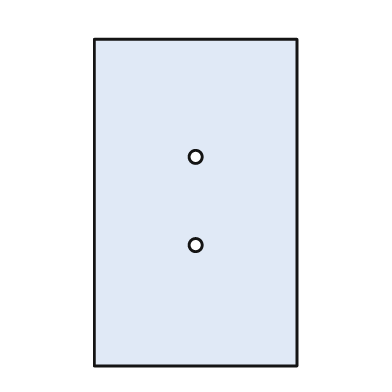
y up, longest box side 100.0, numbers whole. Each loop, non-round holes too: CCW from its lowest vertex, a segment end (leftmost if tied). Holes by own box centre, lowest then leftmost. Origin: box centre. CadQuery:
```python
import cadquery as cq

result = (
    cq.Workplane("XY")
    .moveTo(-31.0, -50.0)
    .lineTo(31.0, -50.0)
    .lineTo(31.0, 50.0)
    .lineTo(-31.0, 50.0)
    .close()
    .moveTo(0.0, -13.0)
    .circle(2.0)
    .moveTo(0.0, 14.0)
    .circle(2.0)
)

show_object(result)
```